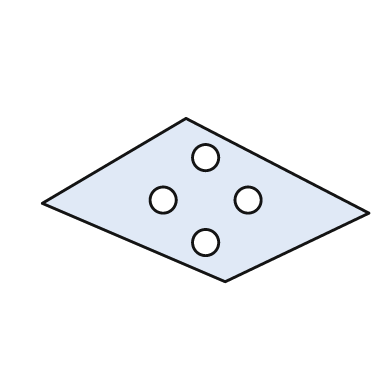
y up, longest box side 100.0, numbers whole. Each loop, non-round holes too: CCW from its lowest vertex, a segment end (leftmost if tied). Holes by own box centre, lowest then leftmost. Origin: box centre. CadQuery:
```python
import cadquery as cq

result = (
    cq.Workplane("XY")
    .moveTo(6.0, -25.0)
    .lineTo(50.0, -4.0)
    .lineTo(-6.0, 25.0)
    .lineTo(-50.0, -1.0)
    .close()
    .moveTo(0.0, -13.0)
    .circle(4.0)
    .moveTo(-13.0, 0.0)
    .circle(4.0)
    .moveTo(13.0, 0.0)
    .circle(4.0)
    .moveTo(0.0, 13.0)
    .circle(4.0)
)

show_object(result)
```